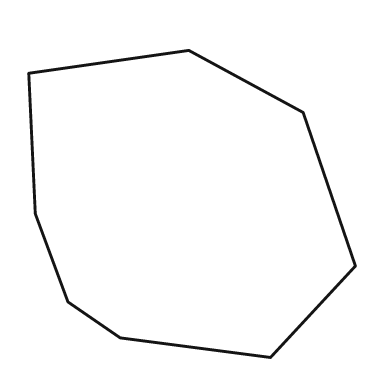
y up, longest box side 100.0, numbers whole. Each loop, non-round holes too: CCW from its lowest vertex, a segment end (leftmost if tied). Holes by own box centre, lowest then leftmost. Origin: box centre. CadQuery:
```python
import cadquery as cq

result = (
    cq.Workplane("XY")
    .moveTo(24.0, -47.0)
    .lineTo(50.0, -19.0)
    .lineTo(34.0, 28.0)
    .lineTo(-1.0, 47.0)
    .lineTo(-50.0, 40.0)
    .lineTo(-48.0, -3.0)
    .lineTo(-38.0, -30.0)
    .lineTo(-22.0, -41.0)
    .close()
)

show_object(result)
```